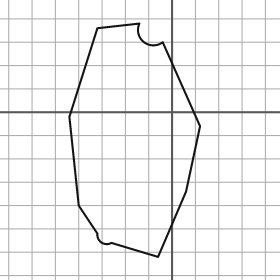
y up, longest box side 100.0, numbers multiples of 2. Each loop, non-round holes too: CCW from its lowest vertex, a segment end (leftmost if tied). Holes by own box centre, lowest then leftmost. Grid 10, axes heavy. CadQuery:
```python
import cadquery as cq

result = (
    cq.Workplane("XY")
    .moveTo(-6.0, -62.0)
    .lineTo(6.0, -34.0)
    .lineTo(12.0, -6.0)
    .lineTo(-4.0, 30.0)
    .threePointArc((-12.0, 30.0), (-14.0, 38.0))
    .lineTo(-32.0, 36.0)
    .lineTo(-44.0, -2.0)
    .lineTo(-40.0, -40.0)
    .lineTo(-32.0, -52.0)
    .threePointArc((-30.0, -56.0), (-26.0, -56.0))
    .close()
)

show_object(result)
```